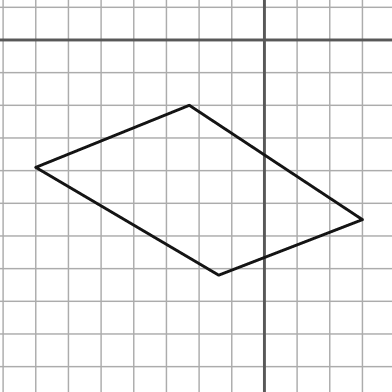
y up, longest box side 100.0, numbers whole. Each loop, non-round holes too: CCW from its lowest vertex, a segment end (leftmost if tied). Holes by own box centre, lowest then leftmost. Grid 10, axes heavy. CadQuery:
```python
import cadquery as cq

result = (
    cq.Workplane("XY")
    .moveTo(-14.0, -72.0)
    .lineTo(30.0, -55.0)
    .lineTo(-23.0, -20.0)
    .lineTo(-70.0, -39.0)
    .close()
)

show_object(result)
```